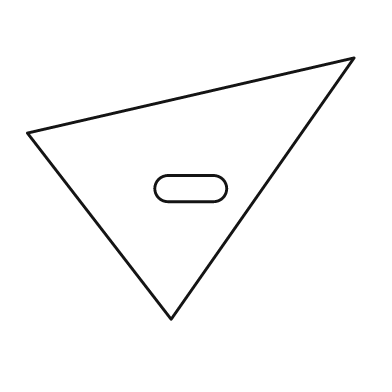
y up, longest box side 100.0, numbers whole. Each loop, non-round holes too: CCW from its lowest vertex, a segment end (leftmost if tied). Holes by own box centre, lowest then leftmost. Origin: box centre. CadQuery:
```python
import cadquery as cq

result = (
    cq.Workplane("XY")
    .moveTo(-6.0, -40.0)
    .lineTo(50.0, 40.0)
    .lineTo(-50.0, 17.0)
    .close()
    .moveTo(-7.0, -4.0)
    .lineTo(7.0, -4.0)
    .threePointArc((11.0, 0.0), (7.0, 4.0))
    .lineTo(-7.0, 4.0)
    .threePointArc((-11.0, 0.0), (-7.0, -4.0))
    .close()
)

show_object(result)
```